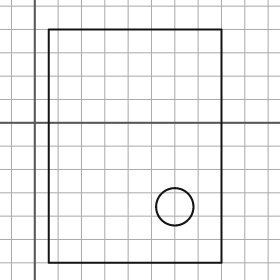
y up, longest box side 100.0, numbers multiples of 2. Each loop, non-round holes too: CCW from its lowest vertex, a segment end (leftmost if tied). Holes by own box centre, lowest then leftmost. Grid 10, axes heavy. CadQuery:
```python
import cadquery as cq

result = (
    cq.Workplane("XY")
    .moveTo(6.0, -60.0)
    .lineTo(80.0, -60.0)
    .lineTo(80.0, 40.0)
    .lineTo(6.0, 40.0)
    .close()
    .moveTo(60.0, -36.0)
    .circle(8.0)
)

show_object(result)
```